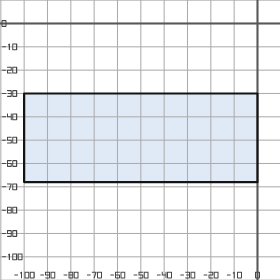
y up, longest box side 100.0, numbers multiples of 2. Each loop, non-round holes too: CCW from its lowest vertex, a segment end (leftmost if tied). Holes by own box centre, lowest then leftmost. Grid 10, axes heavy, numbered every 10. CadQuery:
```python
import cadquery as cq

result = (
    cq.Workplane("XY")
    .moveTo(-100.0, -68.0)
    .lineTo(0.0, -68.0)
    .lineTo(0.0, -30.0)
    .lineTo(-100.0, -30.0)
    .close()
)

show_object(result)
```